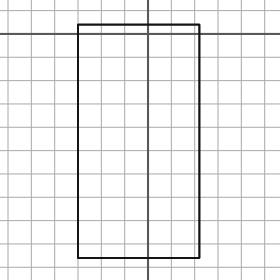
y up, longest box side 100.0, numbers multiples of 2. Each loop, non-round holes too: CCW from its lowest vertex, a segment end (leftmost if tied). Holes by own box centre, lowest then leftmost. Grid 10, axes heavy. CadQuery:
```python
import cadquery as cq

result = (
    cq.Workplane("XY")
    .moveTo(-30.0, -96.0)
    .lineTo(22.0, -96.0)
    .lineTo(22.0, 4.0)
    .lineTo(-30.0, 4.0)
    .close()
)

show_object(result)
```